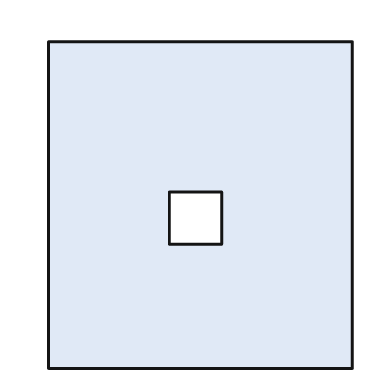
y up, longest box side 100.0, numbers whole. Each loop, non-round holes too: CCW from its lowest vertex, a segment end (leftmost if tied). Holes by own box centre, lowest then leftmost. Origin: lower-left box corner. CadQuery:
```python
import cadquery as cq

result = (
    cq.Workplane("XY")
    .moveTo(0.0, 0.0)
    .lineTo(93.0, 0.0)
    .lineTo(93.0, 100.0)
    .lineTo(0.0, 100.0)
    .close()
    .moveTo(37.0, 38.0)
    .lineTo(53.0, 38.0)
    .lineTo(53.0, 54.0)
    .lineTo(37.0, 54.0)
    .close()
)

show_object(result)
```